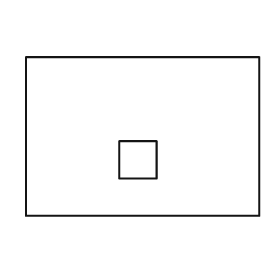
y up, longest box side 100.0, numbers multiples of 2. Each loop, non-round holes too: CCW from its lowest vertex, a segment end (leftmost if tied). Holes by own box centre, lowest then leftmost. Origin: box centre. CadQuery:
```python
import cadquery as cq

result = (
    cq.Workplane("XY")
    .moveTo(-50.0, -34.0)
    .lineTo(50.0, -34.0)
    .lineTo(50.0, 34.0)
    .lineTo(-50.0, 34.0)
    .close()
    .moveTo(-10.0, -18.0)
    .lineTo(6.0, -18.0)
    .lineTo(6.0, -2.0)
    .lineTo(-10.0, -2.0)
    .close()
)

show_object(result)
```